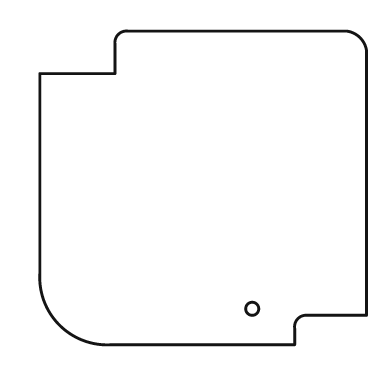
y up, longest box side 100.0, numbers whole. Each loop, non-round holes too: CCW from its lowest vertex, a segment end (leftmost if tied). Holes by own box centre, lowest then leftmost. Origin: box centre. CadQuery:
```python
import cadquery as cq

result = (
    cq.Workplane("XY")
    .moveTo(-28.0, -48.0)
    .lineTo(28.0, -48.0)
    .lineTo(28.0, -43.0)
    .threePointArc((29.0, -40.0), (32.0, -39.0))
    .lineTo(50.0, -39.0)
    .lineTo(50.0, 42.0)
    .threePointArc((48.0, 46.0), (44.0, 48.0))
    .lineTo(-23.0, 48.0)
    .threePointArc((-26.0, 47.0), (-27.0, 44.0))
    .lineTo(-27.0, 35.0)
    .lineTo(-50.0, 35.0)
    .lineTo(-50.0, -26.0)
    .threePointArc((-44.0, -42.0), (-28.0, -48.0))
    .close()
    .moveTo(15.0, -37.0)
    .circle(2.0)
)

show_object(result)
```